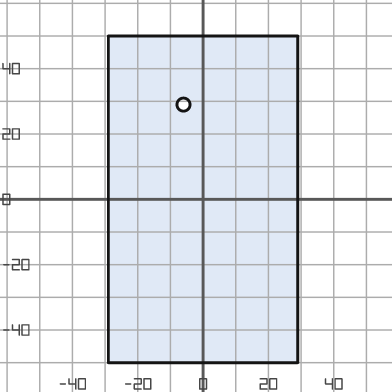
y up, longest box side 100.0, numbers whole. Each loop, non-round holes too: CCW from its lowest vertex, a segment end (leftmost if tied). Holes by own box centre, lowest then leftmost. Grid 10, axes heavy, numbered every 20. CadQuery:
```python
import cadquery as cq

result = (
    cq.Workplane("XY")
    .moveTo(-29.0, -50.0)
    .lineTo(29.0, -50.0)
    .lineTo(29.0, 50.0)
    .lineTo(-29.0, 50.0)
    .close()
    .moveTo(-6.0, 29.0)
    .circle(2.0)
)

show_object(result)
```